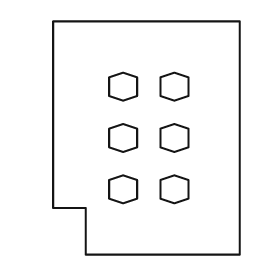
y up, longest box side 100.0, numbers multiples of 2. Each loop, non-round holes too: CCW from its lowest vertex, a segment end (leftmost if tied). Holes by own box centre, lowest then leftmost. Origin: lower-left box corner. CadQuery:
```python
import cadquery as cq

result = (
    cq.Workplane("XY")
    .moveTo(14.0, 0.0)
    .lineTo(80.0, 0.0)
    .lineTo(80.0, 100.0)
    .lineTo(0.0, 100.0)
    .lineTo(0.0, 20.0)
    .lineTo(14.0, 20.0)
    .close()
    .moveTo(30.0, 22.0)
    .lineTo(36.0, 24.0)
    .lineTo(36.0, 32.0)
    .lineTo(30.0, 34.0)
    .lineTo(24.0, 32.0)
    .lineTo(24.0, 24.0)
    .close()
    .moveTo(52.0, 22.0)
    .lineTo(58.0, 24.0)
    .lineTo(58.0, 32.0)
    .lineTo(52.0, 34.0)
    .lineTo(46.0, 32.0)
    .lineTo(46.0, 24.0)
    .close()
    .moveTo(30.0, 44.0)
    .lineTo(36.0, 46.0)
    .lineTo(36.0, 54.0)
    .lineTo(30.0, 56.0)
    .lineTo(24.0, 54.0)
    .lineTo(24.0, 46.0)
    .close()
    .moveTo(52.0, 44.0)
    .lineTo(58.0, 46.0)
    .lineTo(58.0, 54.0)
    .lineTo(52.0, 56.0)
    .lineTo(46.0, 54.0)
    .lineTo(46.0, 46.0)
    .close()
    .moveTo(30.0, 66.0)
    .lineTo(36.0, 68.0)
    .lineTo(36.0, 76.0)
    .lineTo(30.0, 78.0)
    .lineTo(24.0, 76.0)
    .lineTo(24.0, 68.0)
    .close()
    .moveTo(52.0, 66.0)
    .lineTo(58.0, 68.0)
    .lineTo(58.0, 76.0)
    .lineTo(52.0, 78.0)
    .lineTo(46.0, 76.0)
    .lineTo(46.0, 68.0)
    .close()
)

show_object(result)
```